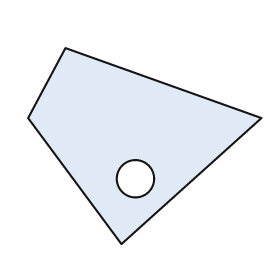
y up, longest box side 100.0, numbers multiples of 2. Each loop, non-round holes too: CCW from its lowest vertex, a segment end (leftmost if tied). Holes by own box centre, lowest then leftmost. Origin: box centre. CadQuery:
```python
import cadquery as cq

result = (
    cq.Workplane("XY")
    .moveTo(-10.0, -42.0)
    .lineTo(50.0, 12.0)
    .lineTo(-34.0, 42.0)
    .lineTo(-50.0, 12.0)
    .close()
    .moveTo(-4.0, -14.0)
    .circle(8.0)
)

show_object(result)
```